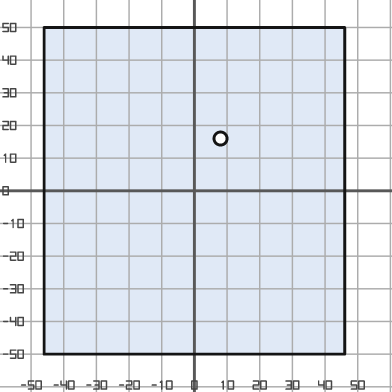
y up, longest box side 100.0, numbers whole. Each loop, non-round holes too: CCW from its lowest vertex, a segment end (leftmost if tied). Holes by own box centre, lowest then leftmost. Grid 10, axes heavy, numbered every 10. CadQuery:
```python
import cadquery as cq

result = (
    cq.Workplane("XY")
    .moveTo(-46.0, -50.0)
    .lineTo(46.0, -50.0)
    .lineTo(46.0, 50.0)
    .lineTo(-46.0, 50.0)
    .close()
    .moveTo(8.0, 16.0)
    .circle(2.0)
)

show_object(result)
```